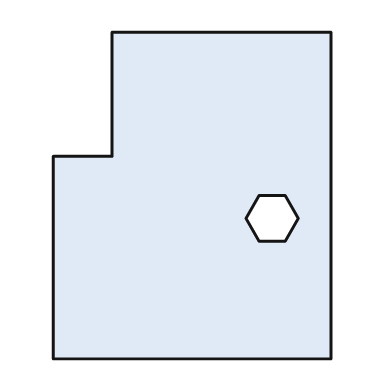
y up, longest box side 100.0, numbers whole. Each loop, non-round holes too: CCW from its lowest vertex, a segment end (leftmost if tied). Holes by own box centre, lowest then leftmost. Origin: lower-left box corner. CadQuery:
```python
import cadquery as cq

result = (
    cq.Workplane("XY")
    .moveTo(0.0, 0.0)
    .lineTo(85.0, 0.0)
    .lineTo(85.0, 100.0)
    .lineTo(18.0, 100.0)
    .lineTo(18.0, 62.0)
    .lineTo(0.0, 62.0)
    .close()
    .moveTo(63.0, 36.0)
    .lineTo(71.0, 36.0)
    .lineTo(75.0, 43.0)
    .lineTo(71.0, 50.0)
    .lineTo(63.0, 50.0)
    .lineTo(59.0, 43.0)
    .close()
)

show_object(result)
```